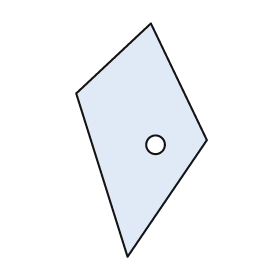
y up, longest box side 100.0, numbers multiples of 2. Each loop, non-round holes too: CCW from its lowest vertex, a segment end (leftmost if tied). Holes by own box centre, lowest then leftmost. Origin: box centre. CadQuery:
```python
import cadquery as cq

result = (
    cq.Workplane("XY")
    .moveTo(-6.0, -50.0)
    .lineTo(28.0, 0.0)
    .lineTo(4.0, 50.0)
    .lineTo(-28.0, 20.0)
    .close()
    .moveTo(6.0, -2.0)
    .circle(4.0)
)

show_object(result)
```